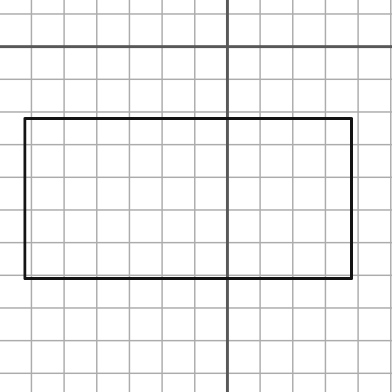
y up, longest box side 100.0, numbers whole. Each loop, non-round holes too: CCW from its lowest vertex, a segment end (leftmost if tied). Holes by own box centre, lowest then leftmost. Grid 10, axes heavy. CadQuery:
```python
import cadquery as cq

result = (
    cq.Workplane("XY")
    .moveTo(-62.0, -71.0)
    .lineTo(38.0, -71.0)
    .lineTo(38.0, -22.0)
    .lineTo(-62.0, -22.0)
    .close()
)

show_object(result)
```